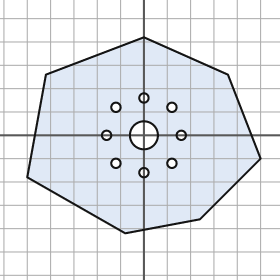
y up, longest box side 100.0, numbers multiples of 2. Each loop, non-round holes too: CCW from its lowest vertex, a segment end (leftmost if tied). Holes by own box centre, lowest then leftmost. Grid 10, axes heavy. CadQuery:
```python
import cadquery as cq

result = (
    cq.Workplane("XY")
    .moveTo(-8.0, -42.0)
    .lineTo(24.0, -36.0)
    .lineTo(50.0, -10.0)
    .lineTo(36.0, 26.0)
    .lineTo(0.0, 42.0)
    .lineTo(-42.0, 26.0)
    .lineTo(-50.0, -18.0)
    .close()
    .moveTo(0.0, -16.0)
    .circle(2.0)
    .moveTo(-12.0, -12.0)
    .circle(2.0)
    .moveTo(12.0, -12.0)
    .circle(2.0)
    .moveTo(-16.0, 0.0)
    .circle(2.0)
    .moveTo(0.0, 0.0)
    .circle(6.0)
    .moveTo(16.0, 0.0)
    .circle(2.0)
    .moveTo(-12.0, 12.0)
    .circle(2.0)
    .moveTo(12.0, 12.0)
    .circle(2.0)
    .moveTo(0.0, 16.0)
    .circle(2.0)
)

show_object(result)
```